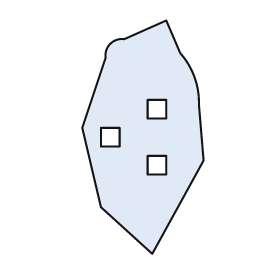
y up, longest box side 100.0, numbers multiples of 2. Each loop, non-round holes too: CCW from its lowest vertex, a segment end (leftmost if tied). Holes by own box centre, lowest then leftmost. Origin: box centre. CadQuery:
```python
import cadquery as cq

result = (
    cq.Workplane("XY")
    .moveTo(4.0, -50.0)
    .lineTo(26.0, -10.0)
    .lineTo(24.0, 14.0)
    .threePointArc((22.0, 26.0), (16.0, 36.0))
    .lineTo(10.0, 50.0)
    .lineTo(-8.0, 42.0)
    .threePointArc((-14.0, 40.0), (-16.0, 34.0))
    .lineTo(-26.0, 4.0)
    .lineTo(-18.0, -30.0)
    .close()
    .moveTo(2.0, -16.0)
    .lineTo(10.0, -16.0)
    .lineTo(10.0, -8.0)
    .lineTo(2.0, -8.0)
    .close()
    .moveTo(-18.0, -4.0)
    .lineTo(-10.0, -4.0)
    .lineTo(-10.0, 4.0)
    .lineTo(-18.0, 4.0)
    .close()
    .moveTo(2.0, 8.0)
    .lineTo(10.0, 8.0)
    .lineTo(10.0, 16.0)
    .lineTo(2.0, 16.0)
    .close()
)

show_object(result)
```